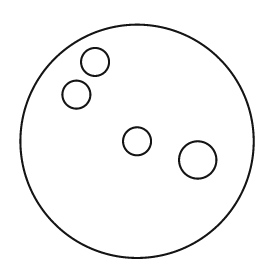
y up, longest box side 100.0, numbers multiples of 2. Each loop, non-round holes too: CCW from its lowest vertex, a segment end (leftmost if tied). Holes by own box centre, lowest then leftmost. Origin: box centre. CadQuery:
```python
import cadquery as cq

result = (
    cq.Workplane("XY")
    .moveTo(0.0, 0.0)
    .circle(50.0)
    .moveTo(26.0, -8.0)
    .circle(8.0)
    .moveTo(0.0, 0.0)
    .circle(6.0)
    .moveTo(-26.0, 20.0)
    .circle(6.0)
    .moveTo(-18.0, 34.0)
    .circle(6.0)
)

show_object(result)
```